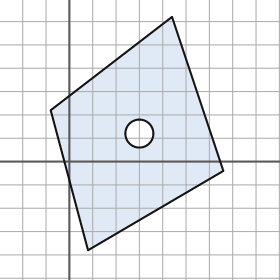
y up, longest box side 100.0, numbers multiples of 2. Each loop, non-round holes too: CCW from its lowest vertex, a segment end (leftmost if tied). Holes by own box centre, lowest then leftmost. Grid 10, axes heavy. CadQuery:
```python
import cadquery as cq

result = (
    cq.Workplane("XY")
    .moveTo(8.0, -38.0)
    .lineTo(66.0, -4.0)
    .lineTo(44.0, 62.0)
    .lineTo(-8.0, 22.0)
    .close()
    .moveTo(30.0, 12.0)
    .circle(6.0)
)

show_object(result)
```